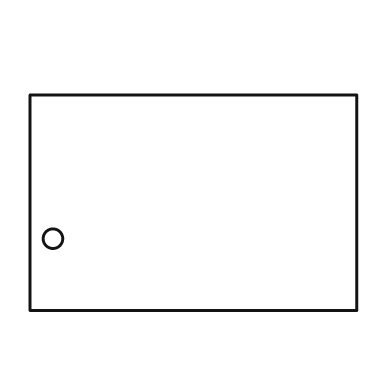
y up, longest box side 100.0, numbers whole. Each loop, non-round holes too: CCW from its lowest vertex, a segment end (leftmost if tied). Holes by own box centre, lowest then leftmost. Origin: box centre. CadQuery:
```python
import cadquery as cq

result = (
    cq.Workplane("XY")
    .moveTo(-50.0, -33.0)
    .lineTo(50.0, -33.0)
    .lineTo(50.0, 33.0)
    .lineTo(-50.0, 33.0)
    .close()
    .moveTo(-43.0, -11.0)
    .circle(3.0)
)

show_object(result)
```